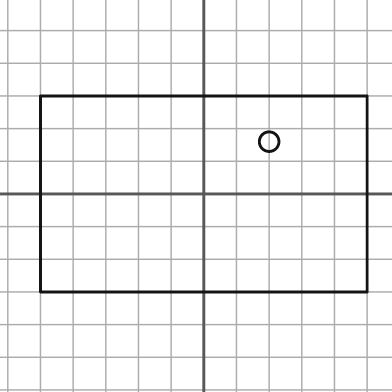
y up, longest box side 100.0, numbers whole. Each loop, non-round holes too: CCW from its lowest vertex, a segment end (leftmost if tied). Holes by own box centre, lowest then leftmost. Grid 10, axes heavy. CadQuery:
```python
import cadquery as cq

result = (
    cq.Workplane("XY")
    .moveTo(-50.0, -30.0)
    .lineTo(50.0, -30.0)
    .lineTo(50.0, 30.0)
    .lineTo(-50.0, 30.0)
    .close()
    .moveTo(20.0, 16.0)
    .circle(3.0)
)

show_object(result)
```